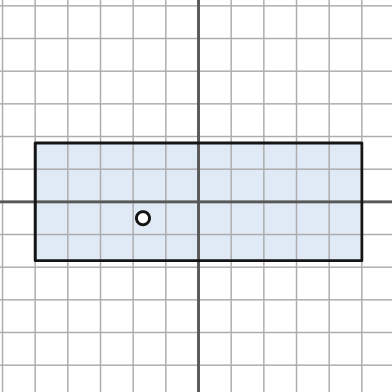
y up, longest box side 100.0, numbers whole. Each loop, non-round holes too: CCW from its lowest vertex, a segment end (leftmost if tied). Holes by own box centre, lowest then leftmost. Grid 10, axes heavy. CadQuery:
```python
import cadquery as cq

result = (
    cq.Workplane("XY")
    .moveTo(-50.0, -18.0)
    .lineTo(50.0, -18.0)
    .lineTo(50.0, 18.0)
    .lineTo(-50.0, 18.0)
    .close()
    .moveTo(-17.0, -5.0)
    .circle(2.0)
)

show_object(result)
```